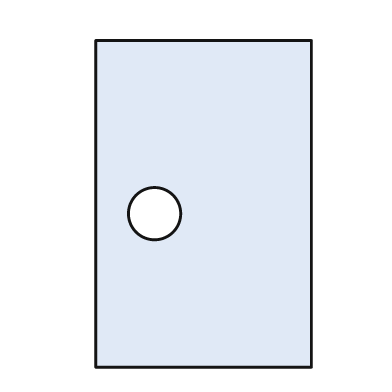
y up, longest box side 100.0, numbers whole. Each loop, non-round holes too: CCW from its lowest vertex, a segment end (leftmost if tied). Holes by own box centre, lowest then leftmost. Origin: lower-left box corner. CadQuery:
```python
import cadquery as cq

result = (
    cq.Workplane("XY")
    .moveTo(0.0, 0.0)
    .lineTo(66.0, 0.0)
    .lineTo(66.0, 100.0)
    .lineTo(0.0, 100.0)
    .close()
    .moveTo(18.0, 47.0)
    .circle(8.0)
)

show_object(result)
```